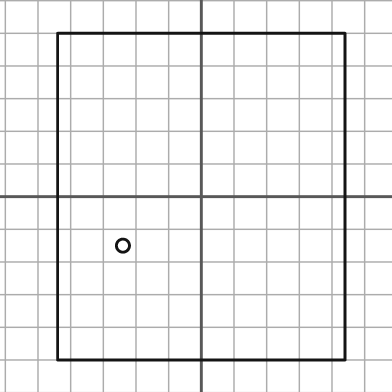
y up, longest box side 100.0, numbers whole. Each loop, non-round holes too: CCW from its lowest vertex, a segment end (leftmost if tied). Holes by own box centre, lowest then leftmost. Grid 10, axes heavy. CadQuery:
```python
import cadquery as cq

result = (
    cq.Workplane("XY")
    .moveTo(-44.0, -50.0)
    .lineTo(44.0, -50.0)
    .lineTo(44.0, 50.0)
    .lineTo(-44.0, 50.0)
    .close()
    .moveTo(-24.0, -15.0)
    .circle(2.0)
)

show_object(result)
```